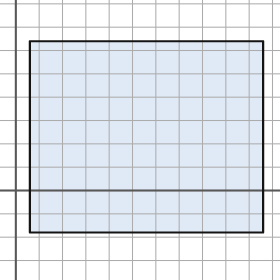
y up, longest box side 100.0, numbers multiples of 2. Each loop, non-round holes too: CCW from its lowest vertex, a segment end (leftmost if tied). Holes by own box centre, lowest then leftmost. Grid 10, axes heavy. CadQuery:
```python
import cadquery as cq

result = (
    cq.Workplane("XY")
    .moveTo(6.0, -18.0)
    .lineTo(106.0, -18.0)
    .lineTo(106.0, 64.0)
    .lineTo(6.0, 64.0)
    .close()
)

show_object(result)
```